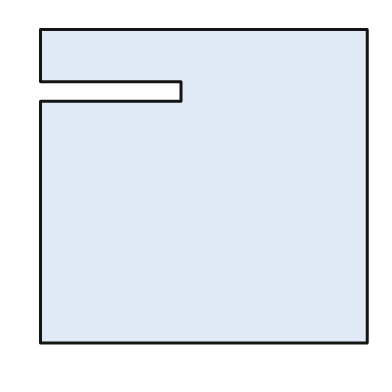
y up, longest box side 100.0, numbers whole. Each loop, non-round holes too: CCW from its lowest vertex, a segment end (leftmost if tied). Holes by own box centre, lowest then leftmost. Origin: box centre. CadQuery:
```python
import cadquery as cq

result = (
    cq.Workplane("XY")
    .moveTo(-50.0, -48.0)
    .lineTo(50.0, -48.0)
    .lineTo(50.0, 48.0)
    .lineTo(-50.0, 48.0)
    .lineTo(-50.0, 32.0)
    .lineTo(-7.0, 32.0)
    .lineTo(-7.0, 26.0)
    .lineTo(-50.0, 26.0)
    .close()
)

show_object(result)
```